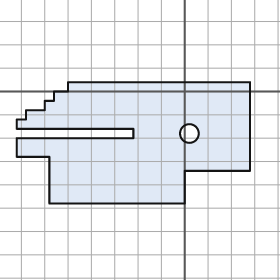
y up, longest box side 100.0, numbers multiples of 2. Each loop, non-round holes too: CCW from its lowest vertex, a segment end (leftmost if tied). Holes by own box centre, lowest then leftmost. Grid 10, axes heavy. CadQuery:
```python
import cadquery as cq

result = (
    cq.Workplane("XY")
    .moveTo(-58.0, -48.0)
    .lineTo(0.0, -48.0)
    .lineTo(0.0, -34.0)
    .lineTo(28.0, -34.0)
    .lineTo(28.0, 4.0)
    .lineTo(-50.0, 4.0)
    .lineTo(-50.0, 0.0)
    .lineTo(-56.0, 0.0)
    .lineTo(-56.0, -4.0)
    .lineTo(-60.0, -4.0)
    .lineTo(-60.0, -8.0)
    .lineTo(-68.0, -8.0)
    .lineTo(-68.0, -12.0)
    .lineTo(-72.0, -12.0)
    .lineTo(-72.0, -16.0)
    .lineTo(-22.0, -16.0)
    .lineTo(-22.0, -20.0)
    .lineTo(-72.0, -20.0)
    .lineTo(-72.0, -28.0)
    .lineTo(-58.0, -28.0)
    .close()
    .moveTo(2.0, -18.0)
    .circle(4.0)
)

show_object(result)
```